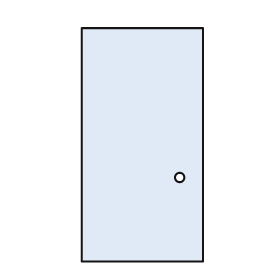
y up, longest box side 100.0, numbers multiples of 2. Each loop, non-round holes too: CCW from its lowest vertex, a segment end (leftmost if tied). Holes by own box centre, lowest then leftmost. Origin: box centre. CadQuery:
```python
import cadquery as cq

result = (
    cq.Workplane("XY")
    .moveTo(-26.0, -50.0)
    .lineTo(26.0, -50.0)
    .lineTo(26.0, 50.0)
    .lineTo(-26.0, 50.0)
    .close()
    .moveTo(16.0, -14.0)
    .circle(2.0)
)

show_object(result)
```